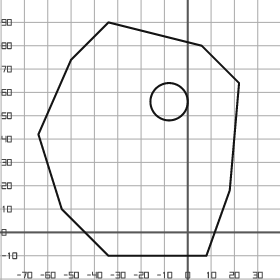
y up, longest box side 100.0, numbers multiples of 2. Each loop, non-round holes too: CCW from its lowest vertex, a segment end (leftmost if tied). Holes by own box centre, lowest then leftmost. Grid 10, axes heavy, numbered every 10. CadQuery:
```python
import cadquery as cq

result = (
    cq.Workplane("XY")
    .moveTo(-34.0, -10.0)
    .lineTo(8.0, -10.0)
    .lineTo(18.0, 18.0)
    .lineTo(22.0, 64.0)
    .lineTo(6.0, 80.0)
    .lineTo(-34.0, 90.0)
    .lineTo(-50.0, 74.0)
    .lineTo(-64.0, 42.0)
    .lineTo(-54.0, 10.0)
    .close()
    .moveTo(-8.0, 56.0)
    .circle(8.0)
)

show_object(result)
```